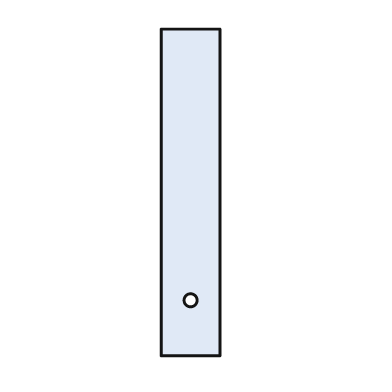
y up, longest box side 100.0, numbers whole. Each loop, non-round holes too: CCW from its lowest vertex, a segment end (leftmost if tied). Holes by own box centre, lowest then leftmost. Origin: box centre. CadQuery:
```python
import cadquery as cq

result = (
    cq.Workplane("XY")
    .moveTo(-9.0, -50.0)
    .lineTo(9.0, -50.0)
    .lineTo(9.0, 50.0)
    .lineTo(-9.0, 50.0)
    .close()
    .moveTo(0.0, -33.0)
    .circle(2.0)
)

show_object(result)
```